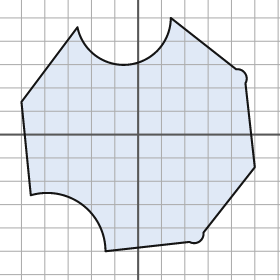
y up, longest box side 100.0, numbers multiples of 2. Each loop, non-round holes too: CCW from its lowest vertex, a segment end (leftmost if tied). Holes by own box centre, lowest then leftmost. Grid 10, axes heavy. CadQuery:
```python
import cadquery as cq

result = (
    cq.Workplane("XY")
    .moveTo(-14.0, -50.0)
    .lineTo(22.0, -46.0)
    .threePointArc((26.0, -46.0), (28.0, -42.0))
    .lineTo(50.0, -14.0)
    .lineTo(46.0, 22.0)
    .threePointArc((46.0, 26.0), (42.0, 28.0))
    .lineTo(14.0, 50.0)
    .threePointArc((-4.0, 30.0), (-26.0, 46.0))
    .lineTo(-50.0, 14.0)
    .lineTo(-46.0, -26.0)
    .threePointArc((-24.0, -30.0), (-14.0, -50.0))
    .close()
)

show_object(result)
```